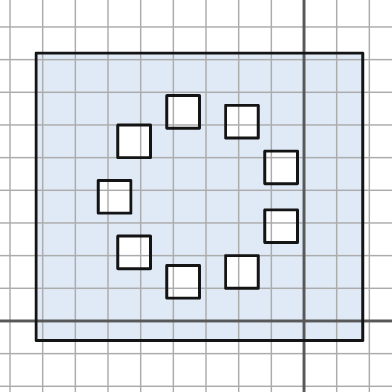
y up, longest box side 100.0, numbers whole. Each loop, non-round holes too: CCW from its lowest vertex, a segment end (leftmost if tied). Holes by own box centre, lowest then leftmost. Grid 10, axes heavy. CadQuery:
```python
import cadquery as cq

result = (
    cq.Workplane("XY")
    .moveTo(-82.0, -6.0)
    .lineTo(18.0, -6.0)
    .lineTo(18.0, 82.0)
    .lineTo(-82.0, 82.0)
    .close()
    .moveTo(-42.0, 7.0)
    .lineTo(-32.0, 7.0)
    .lineTo(-32.0, 17.0)
    .lineTo(-42.0, 17.0)
    .close()
    .moveTo(-24.0, 10.0)
    .lineTo(-14.0, 10.0)
    .lineTo(-14.0, 20.0)
    .lineTo(-24.0, 20.0)
    .close()
    .moveTo(-57.0, 16.0)
    .lineTo(-47.0, 16.0)
    .lineTo(-47.0, 26.0)
    .lineTo(-57.0, 26.0)
    .close()
    .moveTo(-12.0, 24.0)
    .lineTo(-2.0, 24.0)
    .lineTo(-2.0, 34.0)
    .lineTo(-12.0, 34.0)
    .close()
    .moveTo(-63.0, 33.0)
    .lineTo(-53.0, 33.0)
    .lineTo(-53.0, 43.0)
    .lineTo(-63.0, 43.0)
    .close()
    .moveTo(-12.0, 42.0)
    .lineTo(-2.0, 42.0)
    .lineTo(-2.0, 52.0)
    .lineTo(-12.0, 52.0)
    .close()
    .moveTo(-57.0, 50.0)
    .lineTo(-47.0, 50.0)
    .lineTo(-47.0, 60.0)
    .lineTo(-57.0, 60.0)
    .close()
    .moveTo(-24.0, 56.0)
    .lineTo(-14.0, 56.0)
    .lineTo(-14.0, 66.0)
    .lineTo(-24.0, 66.0)
    .close()
    .moveTo(-42.0, 59.0)
    .lineTo(-32.0, 59.0)
    .lineTo(-32.0, 69.0)
    .lineTo(-42.0, 69.0)
    .close()
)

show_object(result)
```